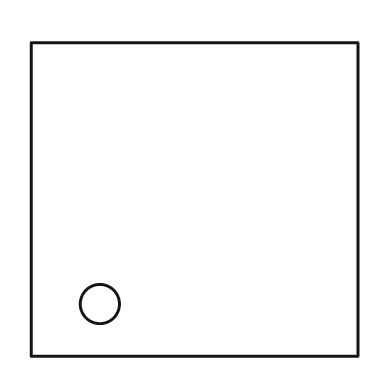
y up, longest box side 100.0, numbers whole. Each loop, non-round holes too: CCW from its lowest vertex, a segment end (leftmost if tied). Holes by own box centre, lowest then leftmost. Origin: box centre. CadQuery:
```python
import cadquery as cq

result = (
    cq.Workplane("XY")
    .moveTo(-50.0, -48.0)
    .lineTo(50.0, -48.0)
    .lineTo(50.0, 48.0)
    .lineTo(-50.0, 48.0)
    .close()
    .moveTo(-29.0, -32.0)
    .circle(6.0)
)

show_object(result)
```